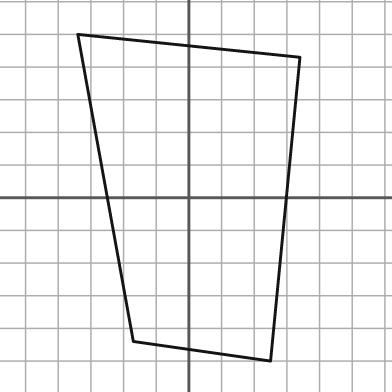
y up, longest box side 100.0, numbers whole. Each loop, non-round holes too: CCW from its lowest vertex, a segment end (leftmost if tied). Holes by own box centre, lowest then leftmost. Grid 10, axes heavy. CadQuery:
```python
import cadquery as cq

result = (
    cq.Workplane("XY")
    .moveTo(25.0, -50.0)
    .lineTo(34.0, 43.0)
    .lineTo(-34.0, 50.0)
    .lineTo(-17.0, -44.0)
    .close()
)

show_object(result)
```